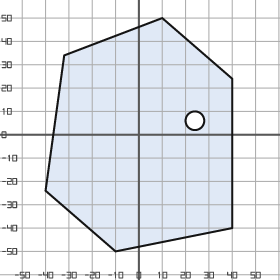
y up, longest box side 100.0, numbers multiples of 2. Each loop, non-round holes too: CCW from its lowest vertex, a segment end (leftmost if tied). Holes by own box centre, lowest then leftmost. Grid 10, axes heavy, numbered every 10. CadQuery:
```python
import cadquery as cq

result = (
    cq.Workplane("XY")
    .moveTo(-10.0, -50.0)
    .lineTo(40.0, -40.0)
    .lineTo(40.0, 24.0)
    .lineTo(10.0, 50.0)
    .lineTo(-32.0, 34.0)
    .lineTo(-40.0, -24.0)
    .close()
    .moveTo(24.0, 6.0)
    .circle(4.0)
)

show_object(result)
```